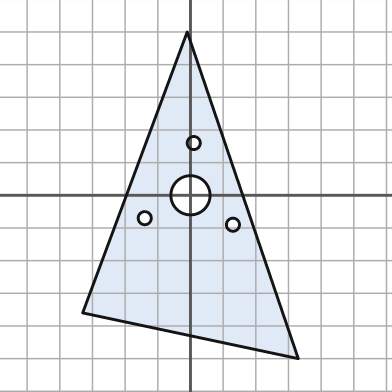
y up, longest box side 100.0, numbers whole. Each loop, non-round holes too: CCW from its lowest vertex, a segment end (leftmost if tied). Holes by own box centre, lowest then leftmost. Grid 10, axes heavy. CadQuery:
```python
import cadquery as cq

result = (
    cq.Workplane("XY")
    .moveTo(33.0, -50.0)
    .lineTo(-1.0, 50.0)
    .lineTo(-33.0, -36.0)
    .close()
    .moveTo(13.0, -9.0)
    .circle(2.0)
    .moveTo(-14.0, -7.0)
    .circle(2.0)
    .moveTo(0.0, 0.0)
    .circle(6.0)
    .moveTo(1.0, 16.0)
    .circle(2.0)
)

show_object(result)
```